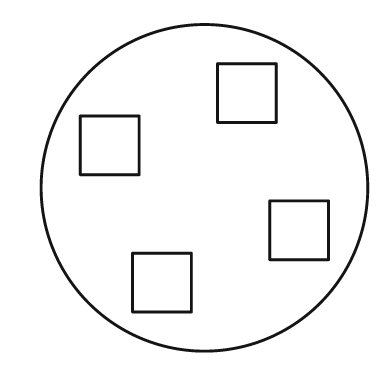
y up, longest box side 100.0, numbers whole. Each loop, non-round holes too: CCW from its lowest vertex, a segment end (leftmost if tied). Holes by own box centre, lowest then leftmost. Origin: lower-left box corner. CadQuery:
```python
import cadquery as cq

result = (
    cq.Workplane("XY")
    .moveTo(50.0, 50.0)
    .circle(50.0)
    .moveTo(28.0, 12.0)
    .lineTo(46.0, 12.0)
    .lineTo(46.0, 30.0)
    .lineTo(28.0, 30.0)
    .close()
    .moveTo(70.0, 28.0)
    .lineTo(88.0, 28.0)
    .lineTo(88.0, 46.0)
    .lineTo(70.0, 46.0)
    .close()
    .moveTo(12.0, 54.0)
    .lineTo(30.0, 54.0)
    .lineTo(30.0, 72.0)
    .lineTo(12.0, 72.0)
    .close()
    .moveTo(54.0, 70.0)
    .lineTo(72.0, 70.0)
    .lineTo(72.0, 88.0)
    .lineTo(54.0, 88.0)
    .close()
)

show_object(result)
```